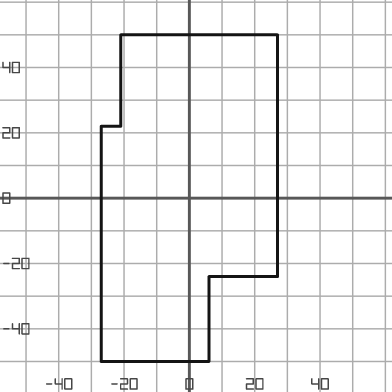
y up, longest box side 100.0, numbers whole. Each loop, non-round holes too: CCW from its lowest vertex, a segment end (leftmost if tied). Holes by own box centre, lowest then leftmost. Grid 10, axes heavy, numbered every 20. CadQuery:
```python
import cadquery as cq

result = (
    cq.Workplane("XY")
    .moveTo(-27.0, -50.0)
    .lineTo(6.0, -50.0)
    .lineTo(6.0, -24.0)
    .lineTo(27.0, -24.0)
    .lineTo(27.0, 50.0)
    .lineTo(-21.0, 50.0)
    .lineTo(-21.0, 22.0)
    .lineTo(-27.0, 22.0)
    .close()
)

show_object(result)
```